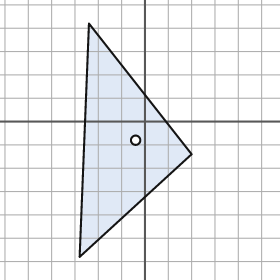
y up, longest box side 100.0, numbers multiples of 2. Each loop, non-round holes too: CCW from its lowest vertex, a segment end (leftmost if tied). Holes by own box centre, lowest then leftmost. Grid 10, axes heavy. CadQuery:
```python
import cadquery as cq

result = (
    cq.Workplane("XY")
    .moveTo(-28.0, -58.0)
    .lineTo(20.0, -14.0)
    .lineTo(-24.0, 42.0)
    .close()
    .moveTo(-4.0, -8.0)
    .circle(2.0)
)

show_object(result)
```